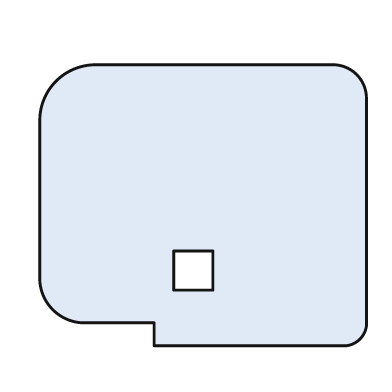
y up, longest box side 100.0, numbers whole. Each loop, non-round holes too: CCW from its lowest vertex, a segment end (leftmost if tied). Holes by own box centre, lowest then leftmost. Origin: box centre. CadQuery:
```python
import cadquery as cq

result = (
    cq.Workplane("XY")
    .moveTo(-15.0, -43.0)
    .lineTo(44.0, -43.0)
    .threePointArc((48.0, -41.0), (50.0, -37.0))
    .lineTo(50.0, 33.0)
    .threePointArc((47.0, 40.0), (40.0, 43.0))
    .lineTo(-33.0, 43.0)
    .threePointArc((-45.0, 38.0), (-50.0, 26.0))
    .lineTo(-50.0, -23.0)
    .threePointArc((-46.0, -32.0), (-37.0, -36.0))
    .lineTo(-15.0, -36.0)
    .close()
    .moveTo(-9.0, -26.0)
    .lineTo(3.0, -26.0)
    .lineTo(3.0, -14.0)
    .lineTo(-9.0, -14.0)
    .close()
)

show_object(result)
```